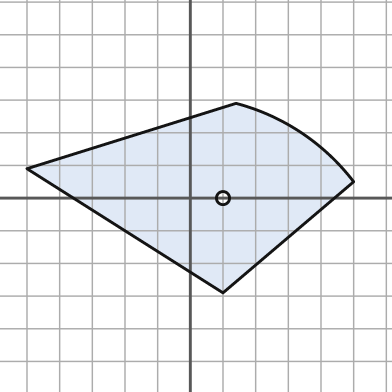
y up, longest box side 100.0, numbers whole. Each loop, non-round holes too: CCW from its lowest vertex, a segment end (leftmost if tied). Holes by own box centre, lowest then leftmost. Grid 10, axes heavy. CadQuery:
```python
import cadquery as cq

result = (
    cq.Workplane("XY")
    .moveTo(10.0, -29.0)
    .lineTo(50.0, 5.0)
    .threePointArc((34.0, 20.0), (14.0, 29.0))
    .lineTo(-50.0, 9.0)
    .close()
    .moveTo(10.0, 0.0)
    .circle(2.0)
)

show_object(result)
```